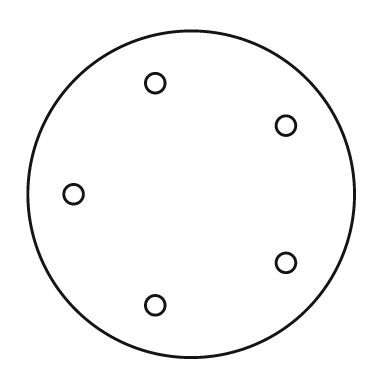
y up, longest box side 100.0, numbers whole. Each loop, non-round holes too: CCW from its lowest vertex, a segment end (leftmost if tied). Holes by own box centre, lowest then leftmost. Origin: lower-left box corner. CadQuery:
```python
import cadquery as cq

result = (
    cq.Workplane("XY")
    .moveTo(50.0, 50.0)
    .circle(50.0)
    .moveTo(39.0, 16.0)
    .circle(3.0)
    .moveTo(79.0, 29.0)
    .circle(3.0)
    .moveTo(14.0, 50.0)
    .circle(3.0)
    .moveTo(79.0, 71.0)
    .circle(3.0)
    .moveTo(39.0, 84.0)
    .circle(3.0)
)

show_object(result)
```